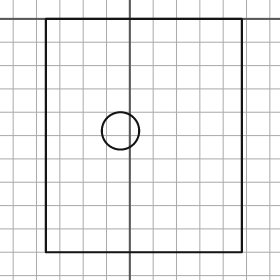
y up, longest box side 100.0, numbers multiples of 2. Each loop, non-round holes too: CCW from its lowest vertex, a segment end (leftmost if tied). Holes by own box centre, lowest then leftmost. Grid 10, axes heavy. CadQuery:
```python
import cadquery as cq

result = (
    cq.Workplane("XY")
    .moveTo(-36.0, -100.0)
    .lineTo(48.0, -100.0)
    .lineTo(48.0, 0.0)
    .lineTo(-36.0, 0.0)
    .close()
    .moveTo(-4.0, -48.0)
    .circle(8.0)
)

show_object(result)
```